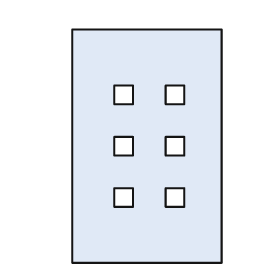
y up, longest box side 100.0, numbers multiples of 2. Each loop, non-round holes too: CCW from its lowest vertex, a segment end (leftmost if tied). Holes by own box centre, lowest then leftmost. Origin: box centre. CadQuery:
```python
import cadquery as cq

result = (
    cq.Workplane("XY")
    .moveTo(-32.0, -50.0)
    .lineTo(32.0, -50.0)
    .lineTo(32.0, 50.0)
    .lineTo(-32.0, 50.0)
    .close()
    .moveTo(-14.0, -26.0)
    .lineTo(-6.0, -26.0)
    .lineTo(-6.0, -18.0)
    .lineTo(-14.0, -18.0)
    .close()
    .moveTo(8.0, -26.0)
    .lineTo(16.0, -26.0)
    .lineTo(16.0, -18.0)
    .lineTo(8.0, -18.0)
    .close()
    .moveTo(-14.0, -4.0)
    .lineTo(-6.0, -4.0)
    .lineTo(-6.0, 4.0)
    .lineTo(-14.0, 4.0)
    .close()
    .moveTo(8.0, -4.0)
    .lineTo(16.0, -4.0)
    .lineTo(16.0, 4.0)
    .lineTo(8.0, 4.0)
    .close()
    .moveTo(-14.0, 18.0)
    .lineTo(-6.0, 18.0)
    .lineTo(-6.0, 26.0)
    .lineTo(-14.0, 26.0)
    .close()
    .moveTo(8.0, 18.0)
    .lineTo(16.0, 18.0)
    .lineTo(16.0, 26.0)
    .lineTo(8.0, 26.0)
    .close()
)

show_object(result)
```